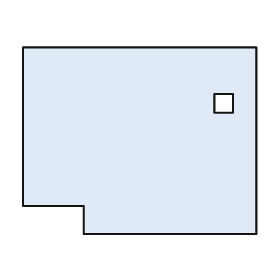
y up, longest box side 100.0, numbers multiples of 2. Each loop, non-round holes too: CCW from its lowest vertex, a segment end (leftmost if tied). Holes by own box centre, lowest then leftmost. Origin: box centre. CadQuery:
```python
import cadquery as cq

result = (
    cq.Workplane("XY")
    .moveTo(-24.0, -40.0)
    .lineTo(50.0, -40.0)
    .lineTo(50.0, 40.0)
    .lineTo(-50.0, 40.0)
    .lineTo(-50.0, -28.0)
    .lineTo(-24.0, -28.0)
    .close()
    .moveTo(32.0, 12.0)
    .lineTo(40.0, 12.0)
    .lineTo(40.0, 20.0)
    .lineTo(32.0, 20.0)
    .close()
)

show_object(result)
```